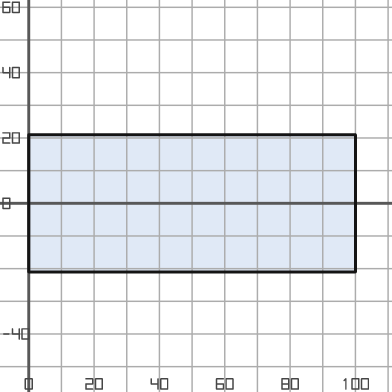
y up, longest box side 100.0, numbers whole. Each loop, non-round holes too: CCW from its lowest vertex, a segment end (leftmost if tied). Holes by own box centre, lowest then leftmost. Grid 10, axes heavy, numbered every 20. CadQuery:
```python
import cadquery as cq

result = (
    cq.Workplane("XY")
    .moveTo(0.0, -21.0)
    .lineTo(100.0, -21.0)
    .lineTo(100.0, 21.0)
    .lineTo(0.0, 21.0)
    .close()
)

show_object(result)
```